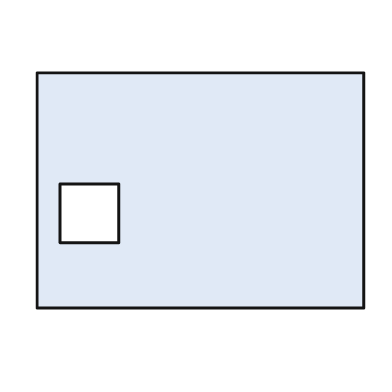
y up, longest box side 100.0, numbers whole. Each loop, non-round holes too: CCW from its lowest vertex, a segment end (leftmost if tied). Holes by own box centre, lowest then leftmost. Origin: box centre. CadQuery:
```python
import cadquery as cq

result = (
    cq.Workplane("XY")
    .moveTo(-50.0, -36.0)
    .lineTo(50.0, -36.0)
    .lineTo(50.0, 36.0)
    .lineTo(-50.0, 36.0)
    .close()
    .moveTo(-43.0, -16.0)
    .lineTo(-25.0, -16.0)
    .lineTo(-25.0, 2.0)
    .lineTo(-43.0, 2.0)
    .close()
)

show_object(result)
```